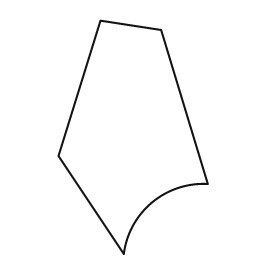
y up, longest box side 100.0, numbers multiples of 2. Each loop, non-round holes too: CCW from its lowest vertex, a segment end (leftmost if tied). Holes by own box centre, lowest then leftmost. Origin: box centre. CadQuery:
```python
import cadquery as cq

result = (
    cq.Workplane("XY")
    .moveTo(-4.0, -50.0)
    .threePointArc((8.0, -28.0), (32.0, -20.0))
    .lineTo(12.0, 46.0)
    .lineTo(-14.0, 50.0)
    .lineTo(-32.0, -8.0)
    .close()
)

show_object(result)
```